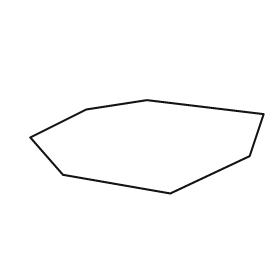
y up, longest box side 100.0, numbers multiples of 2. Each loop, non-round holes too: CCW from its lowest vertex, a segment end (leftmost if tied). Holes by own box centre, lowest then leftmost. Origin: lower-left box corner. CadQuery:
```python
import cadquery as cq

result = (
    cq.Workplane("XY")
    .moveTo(60.0, 0.0)
    .lineTo(94.0, 16.0)
    .lineTo(100.0, 34.0)
    .lineTo(50.0, 40.0)
    .lineTo(24.0, 36.0)
    .lineTo(0.0, 24.0)
    .lineTo(14.0, 8.0)
    .close()
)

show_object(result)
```